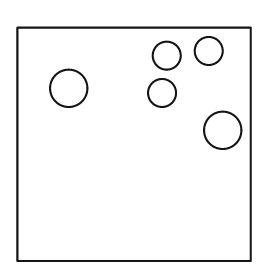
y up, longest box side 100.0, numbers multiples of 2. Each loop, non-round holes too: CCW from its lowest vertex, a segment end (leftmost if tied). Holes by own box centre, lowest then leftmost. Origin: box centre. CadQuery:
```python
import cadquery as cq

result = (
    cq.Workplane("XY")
    .moveTo(-50.0, -50.0)
    .lineTo(50.0, -50.0)
    .lineTo(50.0, 50.0)
    .lineTo(-50.0, 50.0)
    .close()
    .moveTo(38.0, 6.0)
    .circle(8.0)
    .moveTo(12.0, 22.0)
    .circle(6.0)
    .moveTo(-28.0, 24.0)
    .circle(8.0)
    .moveTo(14.0, 38.0)
    .circle(6.0)
    .moveTo(32.0, 40.0)
    .circle(6.0)
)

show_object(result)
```